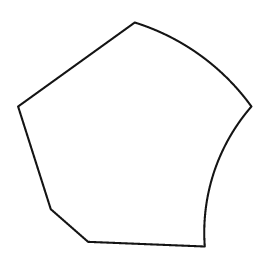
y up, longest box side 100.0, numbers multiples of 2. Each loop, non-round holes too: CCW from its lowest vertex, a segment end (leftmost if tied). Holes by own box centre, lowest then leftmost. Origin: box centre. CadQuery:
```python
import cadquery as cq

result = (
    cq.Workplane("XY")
    .moveTo(30.0, -48.0)
    .threePointArc((34.0, -16.0), (50.0, 12.0))
    .threePointArc((28.0, 34.0), (0.0, 48.0))
    .lineTo(-50.0, 12.0)
    .lineTo(-36.0, -32.0)
    .lineTo(-20.0, -46.0)
    .close()
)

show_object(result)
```